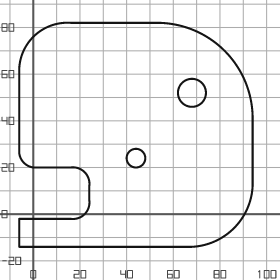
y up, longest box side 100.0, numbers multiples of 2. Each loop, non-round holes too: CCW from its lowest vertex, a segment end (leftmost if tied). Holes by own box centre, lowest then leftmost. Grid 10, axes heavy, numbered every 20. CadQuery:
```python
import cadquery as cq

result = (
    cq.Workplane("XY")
    .moveTo(-6.0, -14.0)
    .lineTo(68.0, -14.0)
    .threePointArc((86.0, -6.0), (94.0, 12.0))
    .lineTo(94.0, 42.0)
    .threePointArc((82.0, 70.0), (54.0, 82.0))
    .lineTo(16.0, 82.0)
    .threePointArc((0.0, 76.0), (-6.0, 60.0))
    .lineTo(-6.0, 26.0)
    .threePointArc((-4.0, 22.0), (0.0, 20.0))
    .lineTo(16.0, 20.0)
    .threePointArc((22.0, 18.0), (24.0, 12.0))
    .lineTo(24.0, 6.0)
    .threePointArc((22.0, 0.0), (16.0, -2.0))
    .lineTo(-6.0, -2.0)
    .close()
    .moveTo(44.0, 24.0)
    .circle(4.0)
    .moveTo(68.0, 52.0)
    .circle(6.0)
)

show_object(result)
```